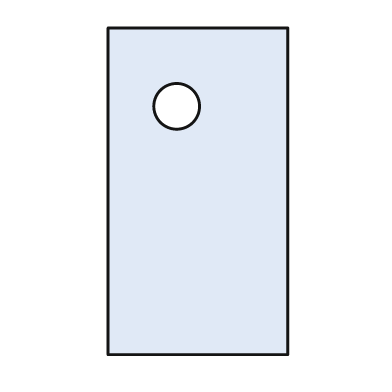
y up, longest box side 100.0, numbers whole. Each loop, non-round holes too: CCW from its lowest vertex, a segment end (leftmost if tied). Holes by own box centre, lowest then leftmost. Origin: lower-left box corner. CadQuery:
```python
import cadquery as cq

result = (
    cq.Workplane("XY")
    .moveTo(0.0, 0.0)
    .lineTo(55.0, 0.0)
    .lineTo(55.0, 100.0)
    .lineTo(0.0, 100.0)
    .close()
    .moveTo(21.0, 76.0)
    .circle(7.0)
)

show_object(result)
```